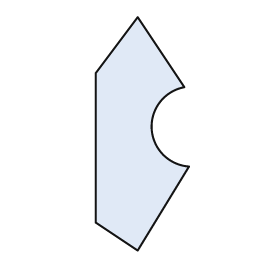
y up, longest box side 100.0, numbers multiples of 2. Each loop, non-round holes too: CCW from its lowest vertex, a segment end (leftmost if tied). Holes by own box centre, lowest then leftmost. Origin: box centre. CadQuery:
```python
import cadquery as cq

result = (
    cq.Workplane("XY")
    .moveTo(-2.0, -50.0)
    .lineTo(20.0, -14.0)
    .threePointArc((4.0, 2.0), (18.0, 20.0))
    .lineTo(-2.0, 50.0)
    .lineTo(-20.0, 26.0)
    .lineTo(-20.0, -38.0)
    .close()
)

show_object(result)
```